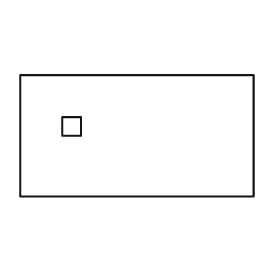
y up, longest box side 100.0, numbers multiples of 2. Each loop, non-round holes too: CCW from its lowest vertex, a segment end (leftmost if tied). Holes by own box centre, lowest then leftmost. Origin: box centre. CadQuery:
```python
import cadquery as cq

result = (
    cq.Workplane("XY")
    .moveTo(-50.0, -26.0)
    .lineTo(50.0, -26.0)
    .lineTo(50.0, 26.0)
    .lineTo(-50.0, 26.0)
    .close()
    .moveTo(-32.0, 0.0)
    .lineTo(-24.0, 0.0)
    .lineTo(-24.0, 8.0)
    .lineTo(-32.0, 8.0)
    .close()
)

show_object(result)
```